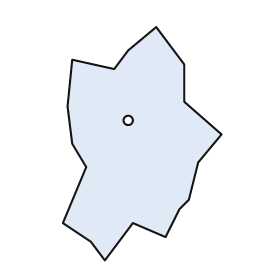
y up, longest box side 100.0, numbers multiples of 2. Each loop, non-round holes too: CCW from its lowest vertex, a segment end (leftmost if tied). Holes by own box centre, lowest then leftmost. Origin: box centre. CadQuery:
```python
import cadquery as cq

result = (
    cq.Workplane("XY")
    .moveTo(-16.0, -50.0)
    .lineTo(-4.0, -34.0)
    .lineTo(10.0, -40.0)
    .lineTo(16.0, -28.0)
    .lineTo(20.0, -24.0)
    .lineTo(24.0, -8.0)
    .lineTo(34.0, 4.0)
    .lineTo(18.0, 18.0)
    .lineTo(18.0, 34.0)
    .lineTo(6.0, 50.0)
    .lineTo(-6.0, 40.0)
    .lineTo(-12.0, 32.0)
    .lineTo(-30.0, 36.0)
    .lineTo(-32.0, 16.0)
    .lineTo(-30.0, 0.0)
    .lineTo(-24.0, -10.0)
    .lineTo(-34.0, -34.0)
    .lineTo(-22.0, -42.0)
    .close()
    .moveTo(-6.0, 10.0)
    .circle(2.0)
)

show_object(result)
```